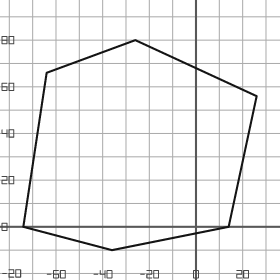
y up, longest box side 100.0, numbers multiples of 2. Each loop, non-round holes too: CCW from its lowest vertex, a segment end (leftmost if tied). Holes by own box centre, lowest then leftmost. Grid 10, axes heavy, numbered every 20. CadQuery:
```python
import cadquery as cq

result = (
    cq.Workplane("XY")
    .moveTo(-36.0, -10.0)
    .lineTo(14.0, 0.0)
    .lineTo(26.0, 56.0)
    .lineTo(-26.0, 80.0)
    .lineTo(-64.0, 66.0)
    .lineTo(-74.0, 0.0)
    .close()
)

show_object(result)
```